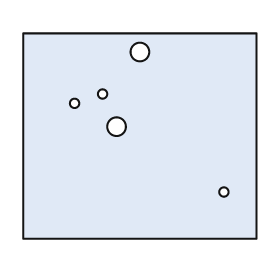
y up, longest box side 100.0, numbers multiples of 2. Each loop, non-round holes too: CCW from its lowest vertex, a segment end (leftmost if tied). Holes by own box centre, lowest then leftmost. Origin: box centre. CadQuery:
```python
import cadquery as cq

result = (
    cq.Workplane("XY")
    .moveTo(-50.0, -44.0)
    .lineTo(50.0, -44.0)
    .lineTo(50.0, 44.0)
    .lineTo(-50.0, 44.0)
    .close()
    .moveTo(36.0, -24.0)
    .circle(2.0)
    .moveTo(-10.0, 4.0)
    .circle(4.0)
    .moveTo(-28.0, 14.0)
    .circle(2.0)
    .moveTo(-16.0, 18.0)
    .circle(2.0)
    .moveTo(0.0, 36.0)
    .circle(4.0)
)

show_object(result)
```